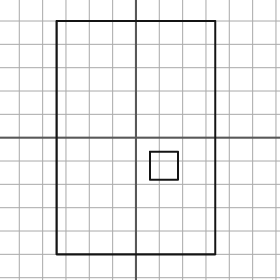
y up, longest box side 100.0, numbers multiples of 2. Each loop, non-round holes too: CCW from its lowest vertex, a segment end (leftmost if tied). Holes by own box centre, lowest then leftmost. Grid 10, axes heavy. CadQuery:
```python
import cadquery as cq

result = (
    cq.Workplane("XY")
    .moveTo(-34.0, -50.0)
    .lineTo(34.0, -50.0)
    .lineTo(34.0, 50.0)
    .lineTo(-34.0, 50.0)
    .close()
    .moveTo(6.0, -18.0)
    .lineTo(18.0, -18.0)
    .lineTo(18.0, -6.0)
    .lineTo(6.0, -6.0)
    .close()
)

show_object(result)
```